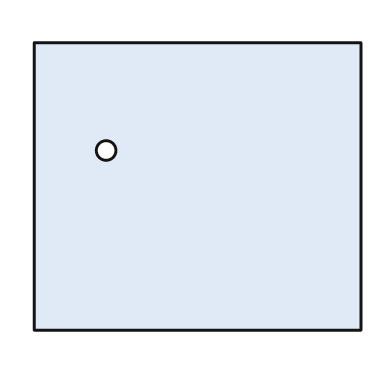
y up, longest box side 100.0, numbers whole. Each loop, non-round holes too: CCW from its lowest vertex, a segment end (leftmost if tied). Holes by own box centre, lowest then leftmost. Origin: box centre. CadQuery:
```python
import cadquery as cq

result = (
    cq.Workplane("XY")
    .moveTo(-50.0, -44.0)
    .lineTo(50.0, -44.0)
    .lineTo(50.0, 44.0)
    .lineTo(-50.0, 44.0)
    .close()
    .moveTo(-28.0, 11.0)
    .circle(3.0)
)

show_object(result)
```